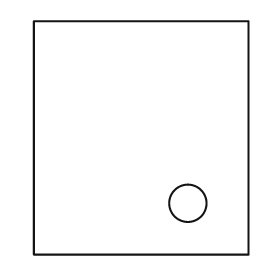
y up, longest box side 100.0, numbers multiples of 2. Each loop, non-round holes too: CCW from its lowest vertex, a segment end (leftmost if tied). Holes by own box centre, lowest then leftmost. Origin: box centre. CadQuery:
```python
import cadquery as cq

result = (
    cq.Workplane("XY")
    .moveTo(-46.0, -50.0)
    .lineTo(46.0, -50.0)
    .lineTo(46.0, 50.0)
    .lineTo(-46.0, 50.0)
    .close()
    .moveTo(20.0, -28.0)
    .circle(8.0)
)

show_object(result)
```